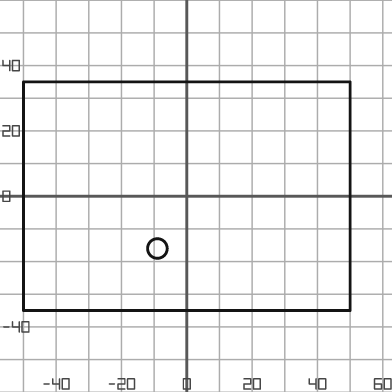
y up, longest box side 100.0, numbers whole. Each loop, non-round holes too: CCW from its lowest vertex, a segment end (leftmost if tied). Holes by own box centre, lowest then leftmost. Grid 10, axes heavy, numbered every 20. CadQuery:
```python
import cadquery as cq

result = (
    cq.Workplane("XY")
    .moveTo(-50.0, -35.0)
    .lineTo(50.0, -35.0)
    .lineTo(50.0, 35.0)
    .lineTo(-50.0, 35.0)
    .close()
    .moveTo(-9.0, -16.0)
    .circle(3.0)
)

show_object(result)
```